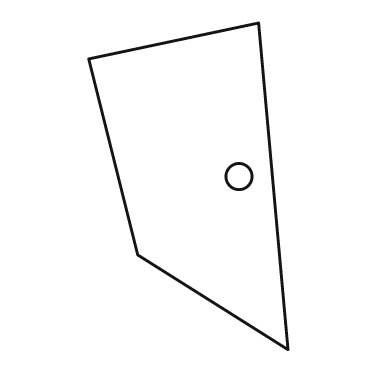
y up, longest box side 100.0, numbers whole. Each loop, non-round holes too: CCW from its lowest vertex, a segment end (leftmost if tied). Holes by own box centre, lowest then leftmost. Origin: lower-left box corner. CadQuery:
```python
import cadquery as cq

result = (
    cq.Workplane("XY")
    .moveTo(61.0, 0.0)
    .lineTo(52.0, 100.0)
    .lineTo(0.0, 89.0)
    .lineTo(15.0, 29.0)
    .close()
    .moveTo(46.0, 53.0)
    .circle(4.0)
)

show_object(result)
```